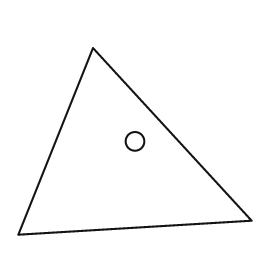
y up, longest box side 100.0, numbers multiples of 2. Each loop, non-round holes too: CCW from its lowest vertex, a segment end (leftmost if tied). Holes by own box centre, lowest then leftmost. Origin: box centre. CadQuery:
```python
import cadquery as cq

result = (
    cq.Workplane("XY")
    .moveTo(-50.0, -40.0)
    .lineTo(50.0, -34.0)
    .lineTo(-18.0, 40.0)
    .close()
    .moveTo(0.0, 0.0)
    .circle(4.0)
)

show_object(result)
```